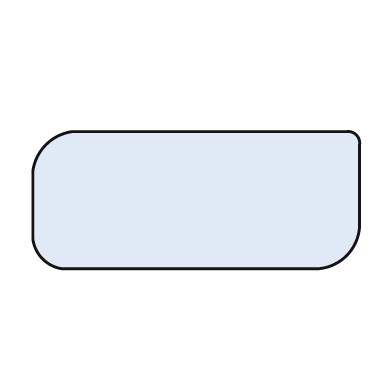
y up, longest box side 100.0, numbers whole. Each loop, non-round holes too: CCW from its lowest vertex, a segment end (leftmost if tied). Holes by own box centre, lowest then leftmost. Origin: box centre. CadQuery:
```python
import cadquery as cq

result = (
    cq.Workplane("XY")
    .moveTo(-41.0, -21.0)
    .lineTo(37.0, -21.0)
    .threePointArc((46.0, -17.0), (50.0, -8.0))
    .lineTo(50.0, 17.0)
    .threePointArc((49.0, 20.0), (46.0, 21.0))
    .lineTo(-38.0, 21.0)
    .threePointArc((-46.0, 17.0), (-50.0, 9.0))
    .lineTo(-50.0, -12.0)
    .threePointArc((-47.0, -18.0), (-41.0, -21.0))
    .close()
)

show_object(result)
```